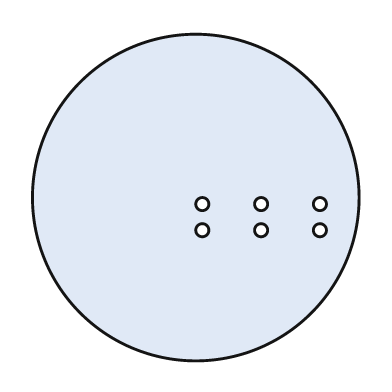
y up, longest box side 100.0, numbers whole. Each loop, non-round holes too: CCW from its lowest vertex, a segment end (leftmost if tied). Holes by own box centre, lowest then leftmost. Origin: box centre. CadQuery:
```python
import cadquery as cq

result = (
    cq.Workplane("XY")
    .moveTo(0.0, 0.0)
    .circle(50.0)
    .moveTo(2.0, -10.0)
    .circle(2.0)
    .moveTo(20.0, -10.0)
    .circle(2.0)
    .moveTo(38.0, -10.0)
    .circle(2.0)
    .moveTo(2.0, -2.0)
    .circle(2.0)
    .moveTo(20.0, -2.0)
    .circle(2.0)
    .moveTo(38.0, -2.0)
    .circle(2.0)
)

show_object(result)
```